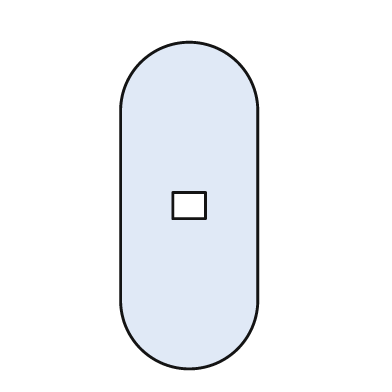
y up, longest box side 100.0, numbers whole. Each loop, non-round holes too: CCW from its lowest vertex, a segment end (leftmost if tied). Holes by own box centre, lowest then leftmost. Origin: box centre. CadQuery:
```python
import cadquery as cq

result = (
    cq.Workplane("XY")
    .moveTo(-21.0, -29.0)
    .threePointArc((0.0, -50.0), (21.0, -29.0))
    .lineTo(21.0, 29.0)
    .threePointArc((0.0, 50.0), (-21.0, 29.0))
    .close()
    .moveTo(-5.0, -4.0)
    .lineTo(5.0, -4.0)
    .lineTo(5.0, 4.0)
    .lineTo(-5.0, 4.0)
    .close()
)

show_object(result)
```